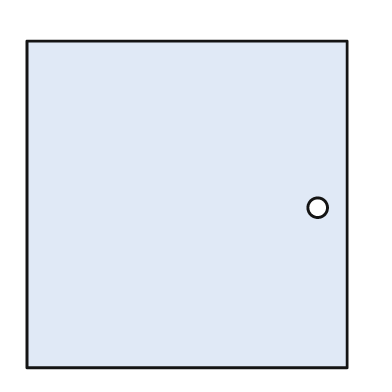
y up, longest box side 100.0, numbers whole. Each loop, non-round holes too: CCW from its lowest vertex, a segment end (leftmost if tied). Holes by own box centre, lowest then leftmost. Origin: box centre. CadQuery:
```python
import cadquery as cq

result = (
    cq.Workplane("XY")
    .moveTo(-49.0, -50.0)
    .lineTo(49.0, -50.0)
    .lineTo(49.0, 50.0)
    .lineTo(-49.0, 50.0)
    .close()
    .moveTo(40.0, -1.0)
    .circle(3.0)
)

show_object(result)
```